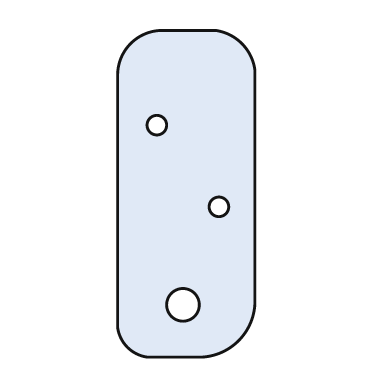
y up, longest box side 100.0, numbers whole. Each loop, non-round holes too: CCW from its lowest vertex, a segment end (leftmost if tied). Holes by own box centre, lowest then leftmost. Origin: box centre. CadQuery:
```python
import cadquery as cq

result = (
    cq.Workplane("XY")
    .moveTo(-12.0, -50.0)
    .lineTo(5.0, -50.0)
    .threePointArc((16.0, -45.0), (21.0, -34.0))
    .lineTo(21.0, 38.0)
    .threePointArc((17.0, 46.0), (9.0, 50.0))
    .lineTo(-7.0, 50.0)
    .threePointArc((-17.0, 46.0), (-21.0, 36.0))
    .lineTo(-21.0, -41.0)
    .threePointArc((-18.0, -47.0), (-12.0, -50.0))
    .close()
    .moveTo(-1.0, -34.0)
    .circle(5.0)
    .moveTo(10.0, -4.0)
    .circle(3.0)
    .moveTo(-9.0, 21.0)
    .circle(3.0)
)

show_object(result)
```